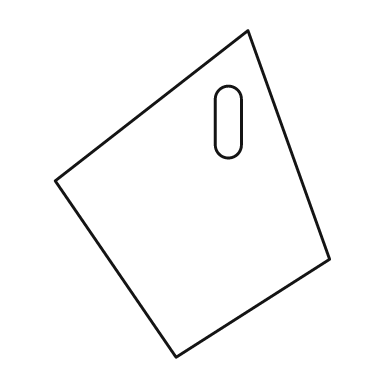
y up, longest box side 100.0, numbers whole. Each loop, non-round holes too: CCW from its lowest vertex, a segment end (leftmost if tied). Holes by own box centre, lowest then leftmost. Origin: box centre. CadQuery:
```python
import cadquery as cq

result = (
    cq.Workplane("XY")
    .moveTo(-5.0, -50.0)
    .lineTo(42.0, -20.0)
    .lineTo(17.0, 50.0)
    .lineTo(-42.0, 4.0)
    .close()
    .moveTo(7.0, 15.0)
    .threePointArc((11.0, 11.0), (15.0, 15.0))
    .lineTo(15.0, 29.0)
    .threePointArc((11.0, 33.0), (7.0, 29.0))
    .close()
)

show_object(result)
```